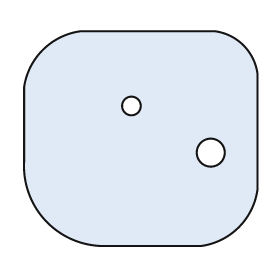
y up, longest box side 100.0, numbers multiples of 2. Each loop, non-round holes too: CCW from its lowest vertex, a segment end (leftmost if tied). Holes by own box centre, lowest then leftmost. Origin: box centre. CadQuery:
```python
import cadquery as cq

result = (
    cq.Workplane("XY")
    .moveTo(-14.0, -46.0)
    .lineTo(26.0, -46.0)
    .threePointArc((42.0, -38.0), (50.0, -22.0))
    .lineTo(50.0, 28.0)
    .threePointArc((44.0, 40.0), (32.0, 46.0))
    .lineTo(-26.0, 46.0)
    .threePointArc((-42.0, 38.0), (-50.0, 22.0))
    .lineTo(-50.0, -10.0)
    .threePointArc((-40.0, -36.0), (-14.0, -46.0))
    .close()
    .moveTo(30.0, -6.0)
    .circle(6.0)
    .moveTo(-4.0, 14.0)
    .circle(4.0)
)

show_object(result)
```